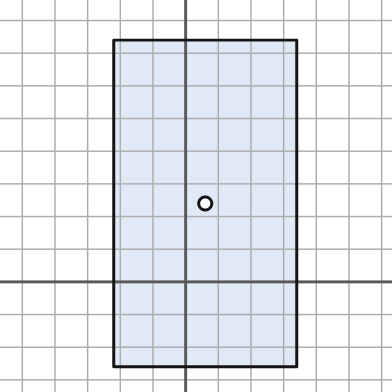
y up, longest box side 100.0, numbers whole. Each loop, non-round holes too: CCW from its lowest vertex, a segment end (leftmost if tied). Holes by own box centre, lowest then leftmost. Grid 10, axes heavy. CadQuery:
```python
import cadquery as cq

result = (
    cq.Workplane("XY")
    .moveTo(-22.0, -26.0)
    .lineTo(34.0, -26.0)
    .lineTo(34.0, 74.0)
    .lineTo(-22.0, 74.0)
    .close()
    .moveTo(6.0, 24.0)
    .circle(2.0)
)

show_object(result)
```